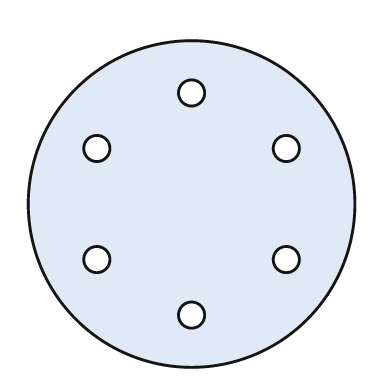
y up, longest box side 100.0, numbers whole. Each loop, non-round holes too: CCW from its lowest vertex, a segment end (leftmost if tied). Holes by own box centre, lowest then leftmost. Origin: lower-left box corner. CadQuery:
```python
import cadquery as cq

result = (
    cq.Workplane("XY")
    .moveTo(50.0, 50.0)
    .circle(50.0)
    .moveTo(50.0, 16.0)
    .circle(4.0)
    .moveTo(21.0, 33.0)
    .circle(4.0)
    .moveTo(79.0, 33.0)
    .circle(4.0)
    .moveTo(21.0, 67.0)
    .circle(4.0)
    .moveTo(79.0, 67.0)
    .circle(4.0)
    .moveTo(50.0, 84.0)
    .circle(4.0)
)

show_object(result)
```